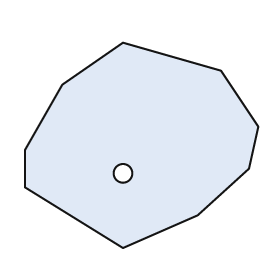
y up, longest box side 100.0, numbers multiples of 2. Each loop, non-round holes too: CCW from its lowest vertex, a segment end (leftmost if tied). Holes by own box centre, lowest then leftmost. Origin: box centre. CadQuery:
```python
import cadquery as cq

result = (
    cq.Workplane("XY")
    .moveTo(-8.0, -44.0)
    .lineTo(24.0, -30.0)
    .lineTo(46.0, -10.0)
    .lineTo(50.0, 8.0)
    .lineTo(34.0, 32.0)
    .lineTo(-8.0, 44.0)
    .lineTo(-34.0, 26.0)
    .lineTo(-50.0, -2.0)
    .lineTo(-50.0, -18.0)
    .close()
    .moveTo(-8.0, -12.0)
    .circle(4.0)
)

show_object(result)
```